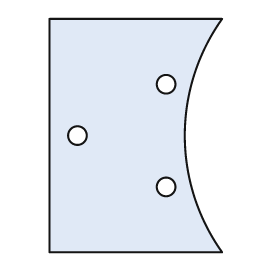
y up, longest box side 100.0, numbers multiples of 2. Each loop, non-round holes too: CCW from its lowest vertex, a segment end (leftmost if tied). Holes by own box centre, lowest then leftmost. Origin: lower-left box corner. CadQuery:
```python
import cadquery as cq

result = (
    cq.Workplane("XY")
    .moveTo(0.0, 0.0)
    .lineTo(74.0, 0.0)
    .threePointArc((58.0, 50.0), (74.0, 100.0))
    .lineTo(0.0, 100.0)
    .close()
    .moveTo(50.0, 28.0)
    .circle(4.0)
    .moveTo(12.0, 50.0)
    .circle(4.0)
    .moveTo(50.0, 72.0)
    .circle(4.0)
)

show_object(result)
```